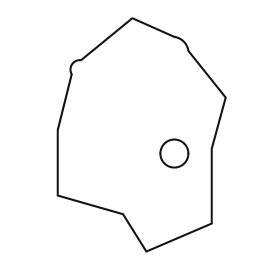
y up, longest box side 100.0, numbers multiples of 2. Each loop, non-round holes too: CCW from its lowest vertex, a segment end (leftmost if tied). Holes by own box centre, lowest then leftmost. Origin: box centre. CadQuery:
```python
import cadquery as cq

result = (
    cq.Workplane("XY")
    .moveTo(2.0, -50.0)
    .lineTo(30.0, -38.0)
    .lineTo(30.0, -6.0)
    .lineTo(36.0, 16.0)
    .lineTo(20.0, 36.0)
    .threePointArc((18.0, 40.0), (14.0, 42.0))
    .lineTo(-4.0, 50.0)
    .lineTo(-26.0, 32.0)
    .threePointArc((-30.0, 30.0), (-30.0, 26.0))
    .lineTo(-36.0, 2.0)
    .lineTo(-36.0, -26.0)
    .lineTo(-8.0, -34.0)
    .close()
    .moveTo(14.0, -8.0)
    .circle(6.0)
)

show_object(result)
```